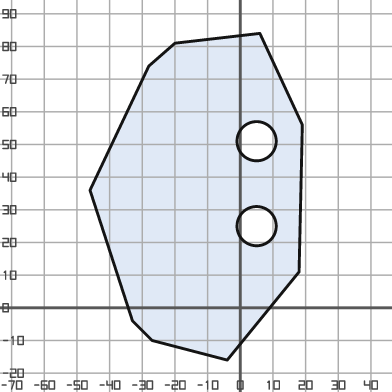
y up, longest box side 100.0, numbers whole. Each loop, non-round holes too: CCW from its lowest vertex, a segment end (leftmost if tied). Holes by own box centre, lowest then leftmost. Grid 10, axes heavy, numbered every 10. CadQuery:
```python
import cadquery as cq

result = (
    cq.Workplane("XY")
    .moveTo(-4.0, -16.0)
    .lineTo(18.0, 11.0)
    .lineTo(19.0, 56.0)
    .lineTo(6.0, 84.0)
    .lineTo(-20.0, 81.0)
    .lineTo(-28.0, 74.0)
    .lineTo(-46.0, 36.0)
    .lineTo(-33.0, -4.0)
    .lineTo(-27.0, -10.0)
    .close()
    .moveTo(5.0, 25.0)
    .circle(6.0)
    .moveTo(5.0, 51.0)
    .circle(6.0)
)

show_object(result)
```